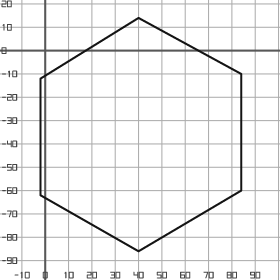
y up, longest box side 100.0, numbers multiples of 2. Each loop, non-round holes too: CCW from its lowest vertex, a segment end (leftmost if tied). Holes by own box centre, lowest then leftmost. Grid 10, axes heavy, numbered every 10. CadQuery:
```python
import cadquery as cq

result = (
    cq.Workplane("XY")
    .moveTo(40.0, -86.0)
    .lineTo(84.0, -60.0)
    .lineTo(84.0, -10.0)
    .lineTo(40.0, 14.0)
    .lineTo(-2.0, -12.0)
    .lineTo(-2.0, -62.0)
    .close()
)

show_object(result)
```